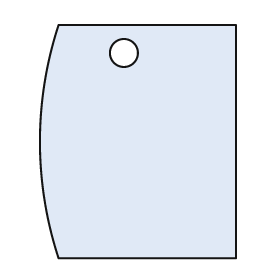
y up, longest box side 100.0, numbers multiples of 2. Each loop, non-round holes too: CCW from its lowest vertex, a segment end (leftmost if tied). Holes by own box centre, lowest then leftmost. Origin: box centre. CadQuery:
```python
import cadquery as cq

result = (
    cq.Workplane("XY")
    .moveTo(-34.0, -50.0)
    .lineTo(42.0, -50.0)
    .lineTo(42.0, 50.0)
    .lineTo(-34.0, 50.0)
    .threePointArc((-42.0, 0.0), (-34.0, -50.0))
    .close()
    .moveTo(-6.0, 38.0)
    .circle(6.0)
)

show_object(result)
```